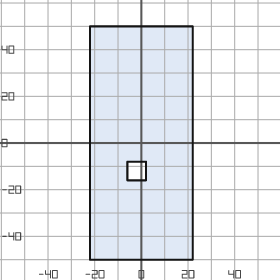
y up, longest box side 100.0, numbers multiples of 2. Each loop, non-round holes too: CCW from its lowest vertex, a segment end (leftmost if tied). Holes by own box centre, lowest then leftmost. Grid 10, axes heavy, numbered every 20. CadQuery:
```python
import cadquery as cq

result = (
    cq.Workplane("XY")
    .moveTo(-22.0, -50.0)
    .lineTo(22.0, -50.0)
    .lineTo(22.0, 50.0)
    .lineTo(-22.0, 50.0)
    .close()
    .moveTo(-6.0, -16.0)
    .lineTo(2.0, -16.0)
    .lineTo(2.0, -8.0)
    .lineTo(-6.0, -8.0)
    .close()
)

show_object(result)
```